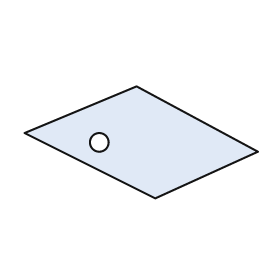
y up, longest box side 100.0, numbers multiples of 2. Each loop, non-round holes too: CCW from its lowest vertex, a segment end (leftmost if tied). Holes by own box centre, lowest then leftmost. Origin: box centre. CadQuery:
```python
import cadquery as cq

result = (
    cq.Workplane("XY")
    .moveTo(6.0, -24.0)
    .lineTo(50.0, -4.0)
    .lineTo(-2.0, 24.0)
    .lineTo(-50.0, 4.0)
    .close()
    .moveTo(-18.0, 0.0)
    .circle(4.0)
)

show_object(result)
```